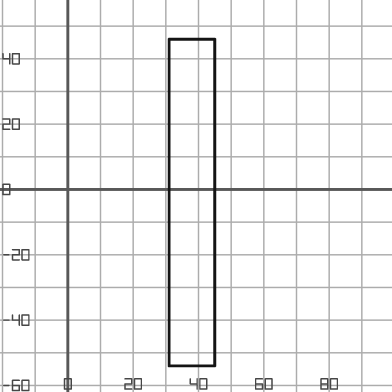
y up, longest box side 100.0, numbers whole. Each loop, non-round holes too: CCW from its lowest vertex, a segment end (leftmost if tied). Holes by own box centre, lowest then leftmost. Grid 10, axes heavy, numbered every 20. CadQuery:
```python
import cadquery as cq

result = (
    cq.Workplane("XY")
    .moveTo(31.0, -54.0)
    .lineTo(45.0, -54.0)
    .lineTo(45.0, 46.0)
    .lineTo(31.0, 46.0)
    .close()
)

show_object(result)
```